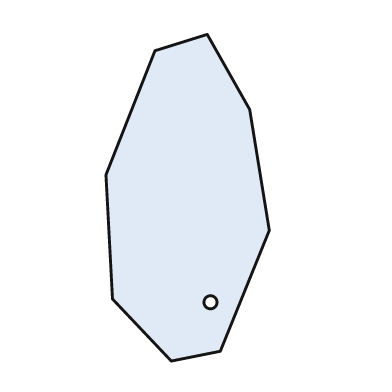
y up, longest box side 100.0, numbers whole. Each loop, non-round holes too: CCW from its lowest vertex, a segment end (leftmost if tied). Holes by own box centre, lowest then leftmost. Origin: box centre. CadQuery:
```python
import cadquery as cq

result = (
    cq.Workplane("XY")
    .moveTo(-5.0, -50.0)
    .lineTo(10.0, -47.0)
    .lineTo(25.0, -10.0)
    .lineTo(19.0, 27.0)
    .lineTo(6.0, 50.0)
    .lineTo(-10.0, 45.0)
    .lineTo(-25.0, 7.0)
    .lineTo(-23.0, -31.0)
    .close()
    .moveTo(7.0, -32.0)
    .circle(2.0)
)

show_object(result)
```